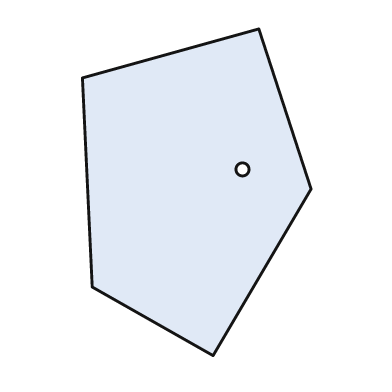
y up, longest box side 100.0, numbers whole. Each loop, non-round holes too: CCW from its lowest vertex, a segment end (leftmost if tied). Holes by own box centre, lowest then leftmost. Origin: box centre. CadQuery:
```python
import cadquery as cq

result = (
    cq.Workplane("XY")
    .moveTo(5.0, -50.0)
    .lineTo(35.0, 1.0)
    .lineTo(19.0, 50.0)
    .lineTo(-35.0, 35.0)
    .lineTo(-32.0, -29.0)
    .close()
    .moveTo(14.0, 7.0)
    .circle(2.0)
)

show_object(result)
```